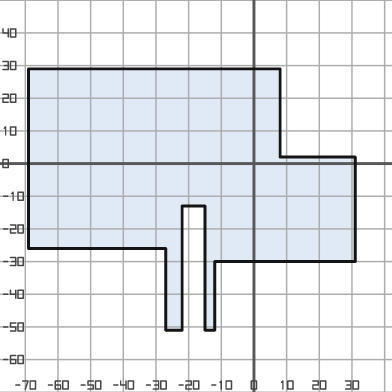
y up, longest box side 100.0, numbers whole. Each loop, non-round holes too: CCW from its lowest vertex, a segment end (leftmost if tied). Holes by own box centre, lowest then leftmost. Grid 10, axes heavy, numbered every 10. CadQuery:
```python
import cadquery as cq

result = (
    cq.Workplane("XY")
    .moveTo(-27.0, -51.0)
    .lineTo(-22.0, -51.0)
    .lineTo(-22.0, -13.0)
    .lineTo(-15.0, -13.0)
    .lineTo(-15.0, -51.0)
    .lineTo(-12.0, -51.0)
    .lineTo(-12.0, -30.0)
    .lineTo(31.0, -30.0)
    .lineTo(31.0, 2.0)
    .lineTo(8.0, 2.0)
    .lineTo(8.0, 29.0)
    .lineTo(-69.0, 29.0)
    .lineTo(-69.0, -26.0)
    .lineTo(-27.0, -26.0)
    .close()
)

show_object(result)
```